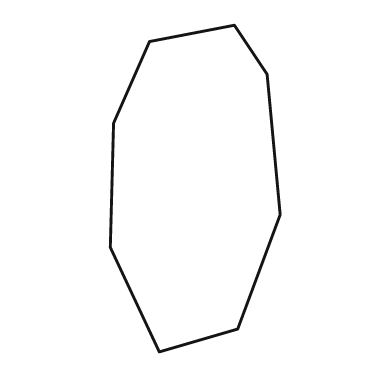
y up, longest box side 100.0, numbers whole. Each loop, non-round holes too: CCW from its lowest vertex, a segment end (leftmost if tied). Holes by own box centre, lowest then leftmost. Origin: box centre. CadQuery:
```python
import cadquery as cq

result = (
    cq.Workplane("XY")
    .moveTo(-11.0, -50.0)
    .lineTo(13.0, -43.0)
    .lineTo(26.0, -8.0)
    .lineTo(22.0, 35.0)
    .lineTo(12.0, 50.0)
    .lineTo(-14.0, 45.0)
    .lineTo(-25.0, 20.0)
    .lineTo(-26.0, -18.0)
    .close()
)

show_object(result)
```